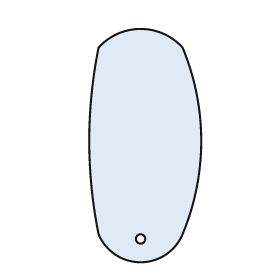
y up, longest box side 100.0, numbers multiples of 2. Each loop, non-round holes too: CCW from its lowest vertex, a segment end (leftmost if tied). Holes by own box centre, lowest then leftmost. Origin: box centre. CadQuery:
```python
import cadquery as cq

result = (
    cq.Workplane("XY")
    .moveTo(-20.0, -38.0)
    .threePointArc((-2.0, -50.0), (16.0, -38.0))
    .threePointArc((24.0, 2.0), (16.0, 42.0))
    .threePointArc((-2.0, 50.0), (-20.0, 42.0))
    .threePointArc((-24.0, 2.0), (-20.0, -38.0))
    .close()
    .moveTo(-2.0, -40.0)
    .circle(2.0)
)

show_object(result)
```